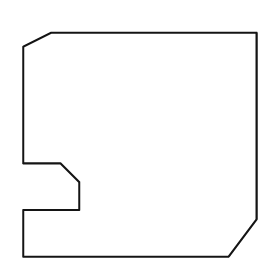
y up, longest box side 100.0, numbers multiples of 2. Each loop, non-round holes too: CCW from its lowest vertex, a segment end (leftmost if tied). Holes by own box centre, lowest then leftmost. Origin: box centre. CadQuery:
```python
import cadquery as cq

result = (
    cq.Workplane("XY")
    .moveTo(-50.0, -48.0)
    .lineTo(38.0, -48.0)
    .lineTo(50.0, -32.0)
    .lineTo(50.0, 48.0)
    .lineTo(-38.0, 48.0)
    .lineTo(-50.0, 42.0)
    .lineTo(-50.0, -8.0)
    .lineTo(-34.0, -8.0)
    .lineTo(-26.0, -16.0)
    .lineTo(-26.0, -28.0)
    .lineTo(-50.0, -28.0)
    .close()
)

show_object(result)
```